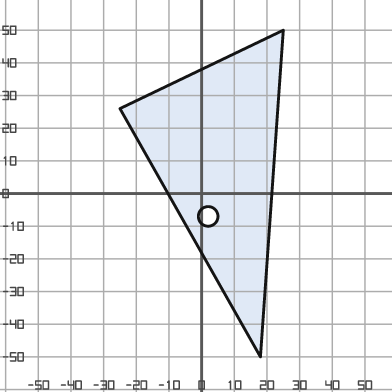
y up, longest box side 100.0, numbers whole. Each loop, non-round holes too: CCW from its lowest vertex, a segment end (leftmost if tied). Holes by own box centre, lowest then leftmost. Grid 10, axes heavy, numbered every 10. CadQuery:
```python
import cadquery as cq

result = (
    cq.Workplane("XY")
    .moveTo(18.0, -50.0)
    .lineTo(25.0, 50.0)
    .lineTo(-25.0, 26.0)
    .close()
    .moveTo(2.0, -7.0)
    .circle(3.0)
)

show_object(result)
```